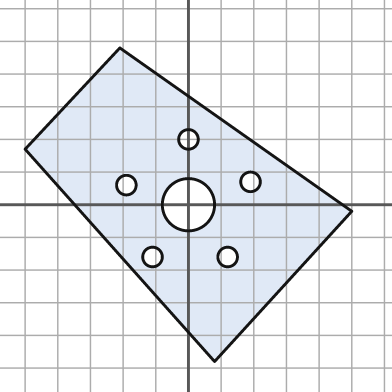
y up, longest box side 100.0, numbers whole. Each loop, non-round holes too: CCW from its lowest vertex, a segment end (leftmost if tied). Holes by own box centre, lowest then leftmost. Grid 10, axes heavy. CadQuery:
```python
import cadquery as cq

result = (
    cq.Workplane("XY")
    .moveTo(8.0, -48.0)
    .lineTo(50.0, -2.0)
    .lineTo(-21.0, 48.0)
    .lineTo(-50.0, 17.0)
    .close()
    .moveTo(-11.0, -16.0)
    .circle(3.0)
    .moveTo(12.0, -16.0)
    .circle(3.0)
    .moveTo(0.0, 0.0)
    .circle(8.0)
    .moveTo(-19.0, 6.0)
    .circle(3.0)
    .moveTo(19.0, 7.0)
    .circle(3.0)
    .moveTo(0.0, 20.0)
    .circle(3.0)
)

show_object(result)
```